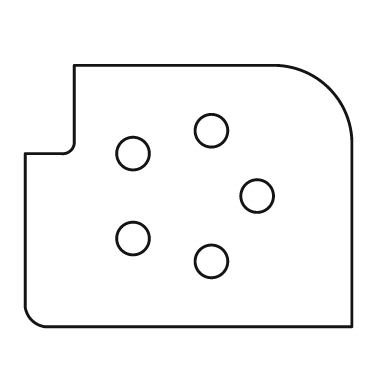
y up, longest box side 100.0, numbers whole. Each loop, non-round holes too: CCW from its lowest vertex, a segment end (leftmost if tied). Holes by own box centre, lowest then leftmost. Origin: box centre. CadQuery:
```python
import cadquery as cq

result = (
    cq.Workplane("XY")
    .moveTo(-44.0, -40.0)
    .lineTo(50.0, -40.0)
    .lineTo(50.0, 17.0)
    .threePointArc((43.0, 33.0), (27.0, 40.0))
    .lineTo(-35.0, 40.0)
    .lineTo(-35.0, 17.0)
    .threePointArc((-36.0, 14.0), (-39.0, 13.0))
    .lineTo(-50.0, 13.0)
    .lineTo(-50.0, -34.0)
    .threePointArc((-48.0, -38.0), (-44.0, -40.0))
    .close()
    .moveTo(7.0, -20.0)
    .circle(5.0)
    .moveTo(-17.0, -13.0)
    .circle(5.0)
    .moveTo(21.0, 0.0)
    .circle(5.0)
    .moveTo(-17.0, 13.0)
    .circle(5.0)
    .moveTo(7.0, 20.0)
    .circle(5.0)
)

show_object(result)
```